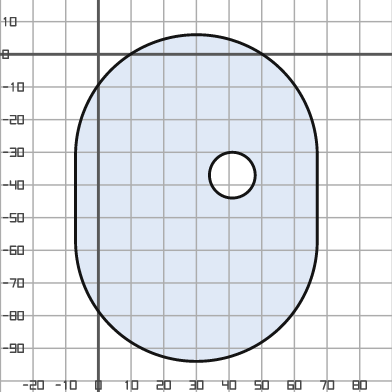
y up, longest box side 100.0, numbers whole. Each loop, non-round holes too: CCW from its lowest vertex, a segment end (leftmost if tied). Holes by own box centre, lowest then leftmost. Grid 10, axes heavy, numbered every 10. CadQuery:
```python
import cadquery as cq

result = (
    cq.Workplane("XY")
    .moveTo(-7.0, -57.0)
    .threePointArc((30.0, -94.0), (67.0, -57.0))
    .lineTo(67.0, -31.0)
    .threePointArc((30.0, 6.0), (-7.0, -31.0))
    .close()
    .moveTo(41.0, -37.0)
    .circle(7.0)
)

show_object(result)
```